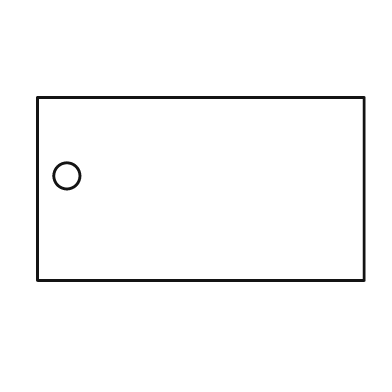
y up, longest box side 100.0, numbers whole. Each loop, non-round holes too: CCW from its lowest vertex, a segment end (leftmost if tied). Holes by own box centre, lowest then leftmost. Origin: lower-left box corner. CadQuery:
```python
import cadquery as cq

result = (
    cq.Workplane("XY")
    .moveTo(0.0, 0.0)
    .lineTo(100.0, 0.0)
    .lineTo(100.0, 56.0)
    .lineTo(0.0, 56.0)
    .close()
    .moveTo(9.0, 32.0)
    .circle(4.0)
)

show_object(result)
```